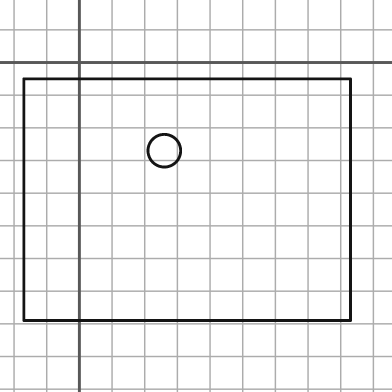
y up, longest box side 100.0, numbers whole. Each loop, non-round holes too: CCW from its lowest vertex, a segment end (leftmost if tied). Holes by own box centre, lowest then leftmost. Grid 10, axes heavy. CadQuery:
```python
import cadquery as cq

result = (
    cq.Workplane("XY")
    .moveTo(-17.0, -79.0)
    .lineTo(83.0, -79.0)
    .lineTo(83.0, -5.0)
    .lineTo(-17.0, -5.0)
    .close()
    .moveTo(26.0, -27.0)
    .circle(5.0)
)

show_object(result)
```